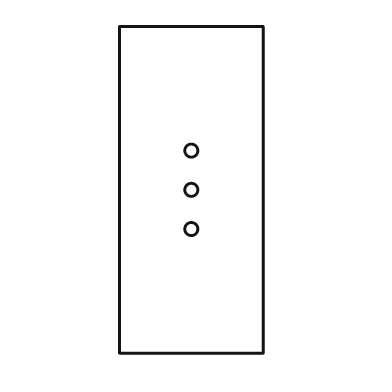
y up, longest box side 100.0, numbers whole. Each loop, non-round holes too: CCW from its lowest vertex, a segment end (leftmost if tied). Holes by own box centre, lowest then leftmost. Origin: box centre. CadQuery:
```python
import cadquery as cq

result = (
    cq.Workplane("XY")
    .moveTo(-22.0, -50.0)
    .lineTo(22.0, -50.0)
    .lineTo(22.0, 50.0)
    .lineTo(-22.0, 50.0)
    .close()
    .moveTo(0.0, -12.0)
    .circle(2.0)
    .moveTo(0.0, 0.0)
    .circle(2.0)
    .moveTo(0.0, 12.0)
    .circle(2.0)
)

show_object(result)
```